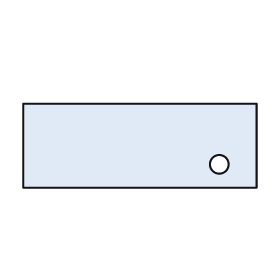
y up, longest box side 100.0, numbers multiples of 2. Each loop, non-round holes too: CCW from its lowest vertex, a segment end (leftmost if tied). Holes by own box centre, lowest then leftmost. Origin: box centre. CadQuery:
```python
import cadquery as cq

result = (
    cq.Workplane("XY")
    .moveTo(-50.0, -18.0)
    .lineTo(50.0, -18.0)
    .lineTo(50.0, 18.0)
    .lineTo(-50.0, 18.0)
    .close()
    .moveTo(34.0, -8.0)
    .circle(4.0)
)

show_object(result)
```